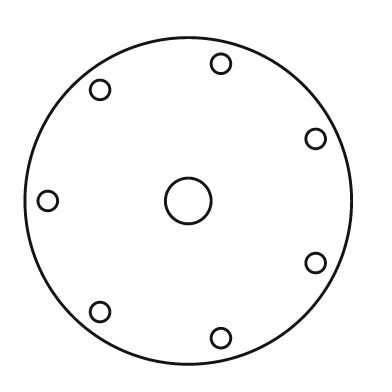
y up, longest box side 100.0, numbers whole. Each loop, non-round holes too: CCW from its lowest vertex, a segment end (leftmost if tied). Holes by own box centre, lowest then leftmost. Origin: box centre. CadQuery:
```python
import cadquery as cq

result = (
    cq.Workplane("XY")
    .moveTo(0.0, 0.0)
    .circle(50.0)
    .moveTo(10.0, -42.0)
    .circle(3.0)
    .moveTo(-27.0, -34.0)
    .circle(3.0)
    .moveTo(39.0, -19.0)
    .circle(3.0)
    .moveTo(-43.0, 0.0)
    .circle(3.0)
    .moveTo(0.0, 0.0)
    .circle(7.0)
    .moveTo(39.0, 19.0)
    .circle(3.0)
    .moveTo(-27.0, 34.0)
    .circle(3.0)
    .moveTo(10.0, 42.0)
    .circle(3.0)
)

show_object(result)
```